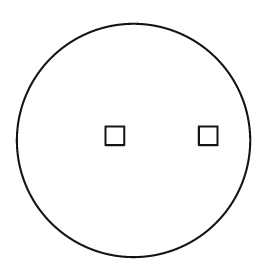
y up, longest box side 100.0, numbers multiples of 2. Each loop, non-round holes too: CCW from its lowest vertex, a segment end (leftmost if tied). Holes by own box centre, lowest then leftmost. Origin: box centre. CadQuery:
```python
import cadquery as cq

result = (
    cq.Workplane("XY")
    .moveTo(0.0, 0.0)
    .circle(50.0)
    .moveTo(-12.0, -2.0)
    .lineTo(-4.0, -2.0)
    .lineTo(-4.0, 6.0)
    .lineTo(-12.0, 6.0)
    .close()
    .moveTo(28.0, -2.0)
    .lineTo(36.0, -2.0)
    .lineTo(36.0, 6.0)
    .lineTo(28.0, 6.0)
    .close()
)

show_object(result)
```